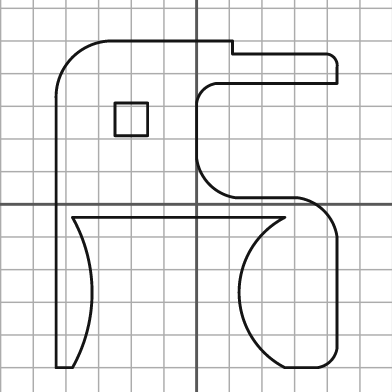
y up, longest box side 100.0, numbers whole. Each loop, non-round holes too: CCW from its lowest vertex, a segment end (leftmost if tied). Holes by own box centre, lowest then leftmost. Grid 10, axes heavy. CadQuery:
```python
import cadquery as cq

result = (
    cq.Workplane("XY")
    .moveTo(-43.0, -50.0)
    .lineTo(-38.0, -50.0)
    .threePointArc((-32.0, -27.0), (-38.0, -4.0))
    .lineTo(27.0, -4.0)
    .threePointArc((13.0, -27.0), (27.0, -50.0))
    .lineTo(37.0, -50.0)
    .threePointArc((41.0, -48.0), (43.0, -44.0))
    .lineTo(43.0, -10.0)
    .threePointArc((39.0, -2.0), (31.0, 2.0))
    .lineTo(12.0, 2.0)
    .threePointArc((4.0, 6.0), (0.0, 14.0))
    .lineTo(0.0, 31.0)
    .threePointArc((2.0, 35.0), (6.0, 37.0))
    .lineTo(43.0, 37.0)
    .lineTo(43.0, 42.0)
    .threePointArc((42.0, 45.0), (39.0, 46.0))
    .lineTo(11.0, 46.0)
    .lineTo(11.0, 50.0)
    .lineTo(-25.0, 50.0)
    .threePointArc((-38.0, 45.0), (-43.0, 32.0))
    .close()
    .moveTo(-25.0, 21.0)
    .lineTo(-15.0, 21.0)
    .lineTo(-15.0, 31.0)
    .lineTo(-25.0, 31.0)
    .close()
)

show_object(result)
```